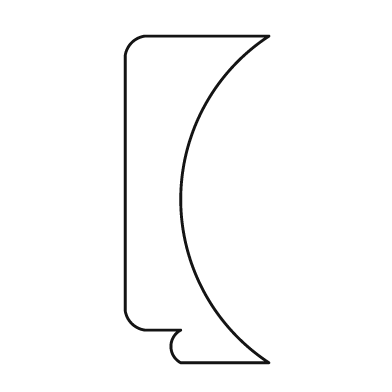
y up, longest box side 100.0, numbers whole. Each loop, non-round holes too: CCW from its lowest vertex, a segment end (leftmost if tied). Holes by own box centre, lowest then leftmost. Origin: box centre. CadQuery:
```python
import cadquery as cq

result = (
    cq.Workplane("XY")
    .moveTo(-5.0, -50.0)
    .lineTo(22.0, -50.0)
    .threePointArc((-5.0, 0.0), (22.0, 50.0))
    .lineTo(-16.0, 50.0)
    .threePointArc((-20.0, 48.0), (-22.0, 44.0))
    .lineTo(-22.0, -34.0)
    .threePointArc((-20.0, -38.0), (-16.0, -40.0))
    .lineTo(-5.0, -40.0)
    .threePointArc((-8.0, -45.0), (-5.0, -50.0))
    .close()
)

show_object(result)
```